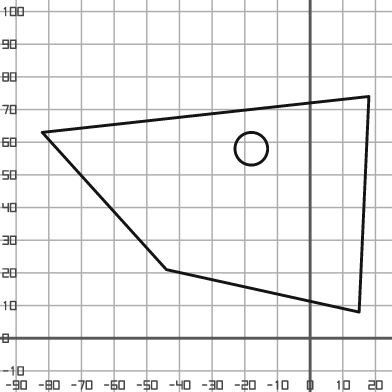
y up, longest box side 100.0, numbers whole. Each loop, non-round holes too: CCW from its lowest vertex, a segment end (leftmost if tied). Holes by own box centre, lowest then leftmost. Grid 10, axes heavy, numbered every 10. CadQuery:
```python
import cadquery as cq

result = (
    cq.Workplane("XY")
    .moveTo(15.0, 8.0)
    .lineTo(18.0, 74.0)
    .lineTo(-82.0, 63.0)
    .lineTo(-44.0, 21.0)
    .close()
    .moveTo(-18.0, 58.0)
    .circle(5.0)
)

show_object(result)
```